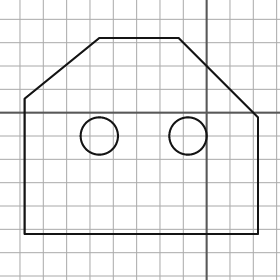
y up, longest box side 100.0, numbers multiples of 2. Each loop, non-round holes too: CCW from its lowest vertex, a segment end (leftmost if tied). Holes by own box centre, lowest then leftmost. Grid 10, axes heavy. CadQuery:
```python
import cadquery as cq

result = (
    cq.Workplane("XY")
    .moveTo(-78.0, -52.0)
    .lineTo(22.0, -52.0)
    .lineTo(22.0, -2.0)
    .lineTo(-12.0, 32.0)
    .lineTo(-46.0, 32.0)
    .lineTo(-78.0, 6.0)
    .close()
    .moveTo(-46.0, -10.0)
    .circle(8.0)
    .moveTo(-8.0, -10.0)
    .circle(8.0)
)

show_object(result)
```